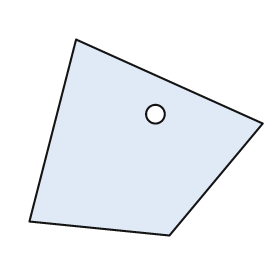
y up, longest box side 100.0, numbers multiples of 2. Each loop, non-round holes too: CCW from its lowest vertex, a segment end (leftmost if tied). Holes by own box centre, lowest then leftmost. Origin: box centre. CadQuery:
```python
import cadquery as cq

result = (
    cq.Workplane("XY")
    .moveTo(10.0, -42.0)
    .lineTo(50.0, 6.0)
    .lineTo(-30.0, 42.0)
    .lineTo(-50.0, -36.0)
    .close()
    .moveTo(4.0, 10.0)
    .circle(4.0)
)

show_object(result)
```